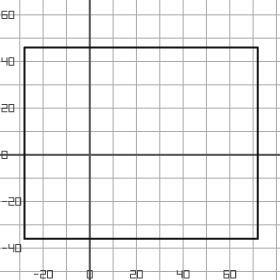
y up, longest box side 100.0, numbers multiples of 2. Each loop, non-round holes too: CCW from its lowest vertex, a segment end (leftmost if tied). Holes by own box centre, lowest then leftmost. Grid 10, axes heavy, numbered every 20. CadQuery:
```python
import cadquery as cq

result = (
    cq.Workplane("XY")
    .moveTo(-28.0, -36.0)
    .lineTo(72.0, -36.0)
    .lineTo(72.0, 46.0)
    .lineTo(-28.0, 46.0)
    .close()
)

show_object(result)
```